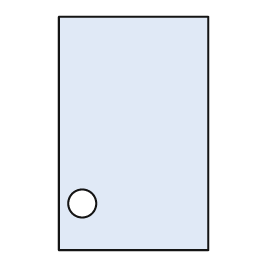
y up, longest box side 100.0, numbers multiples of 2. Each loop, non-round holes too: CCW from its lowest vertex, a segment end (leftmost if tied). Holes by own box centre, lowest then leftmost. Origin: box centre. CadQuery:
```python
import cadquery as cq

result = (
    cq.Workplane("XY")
    .moveTo(-32.0, -50.0)
    .lineTo(32.0, -50.0)
    .lineTo(32.0, 50.0)
    .lineTo(-32.0, 50.0)
    .close()
    .moveTo(-22.0, -30.0)
    .circle(6.0)
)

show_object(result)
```